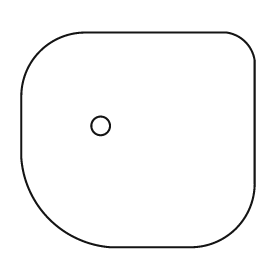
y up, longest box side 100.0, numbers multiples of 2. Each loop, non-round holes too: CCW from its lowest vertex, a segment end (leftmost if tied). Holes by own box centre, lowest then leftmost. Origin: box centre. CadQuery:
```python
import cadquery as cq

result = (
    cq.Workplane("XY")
    .moveTo(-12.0, -46.0)
    .lineTo(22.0, -46.0)
    .threePointArc((42.0, -38.0), (50.0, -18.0))
    .lineTo(50.0, 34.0)
    .threePointArc((46.0, 42.0), (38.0, 46.0))
    .lineTo(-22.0, 46.0)
    .threePointArc((-42.0, 38.0), (-50.0, 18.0))
    .lineTo(-50.0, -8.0)
    .threePointArc((-38.0, -34.0), (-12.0, -46.0))
    .close()
    .moveTo(-16.0, 6.0)
    .circle(4.0)
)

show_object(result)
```